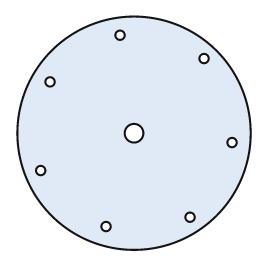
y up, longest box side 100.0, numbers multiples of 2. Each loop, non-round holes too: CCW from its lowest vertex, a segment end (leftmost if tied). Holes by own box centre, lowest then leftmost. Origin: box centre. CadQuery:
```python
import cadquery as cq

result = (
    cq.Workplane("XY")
    .moveTo(0.0, 0.0)
    .circle(50.0)
    .moveTo(-12.0, -40.0)
    .circle(2.0)
    .moveTo(24.0, -36.0)
    .circle(2.0)
    .moveTo(-40.0, -16.0)
    .circle(2.0)
    .moveTo(42.0, -4.0)
    .circle(2.0)
    .moveTo(0.0, 0.0)
    .circle(4.0)
    .moveTo(-36.0, 22.0)
    .circle(2.0)
    .moveTo(30.0, 32.0)
    .circle(2.0)
    .moveTo(-6.0, 42.0)
    .circle(2.0)
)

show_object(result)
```